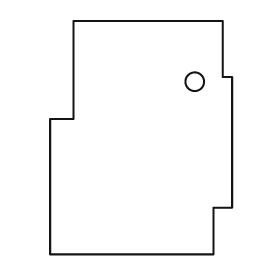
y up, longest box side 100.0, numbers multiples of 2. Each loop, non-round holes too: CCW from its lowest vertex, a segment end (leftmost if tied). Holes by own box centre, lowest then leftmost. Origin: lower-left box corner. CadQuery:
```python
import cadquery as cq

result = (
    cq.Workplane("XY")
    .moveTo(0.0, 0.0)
    .lineTo(70.0, 0.0)
    .lineTo(70.0, 20.0)
    .lineTo(78.0, 20.0)
    .lineTo(78.0, 76.0)
    .lineTo(74.0, 76.0)
    .lineTo(74.0, 100.0)
    .lineTo(10.0, 100.0)
    .lineTo(10.0, 58.0)
    .lineTo(0.0, 58.0)
    .close()
    .moveTo(62.0, 74.0)
    .circle(4.0)
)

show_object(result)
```